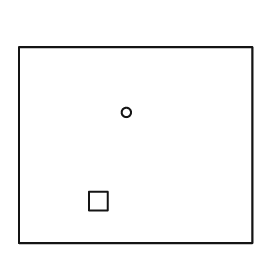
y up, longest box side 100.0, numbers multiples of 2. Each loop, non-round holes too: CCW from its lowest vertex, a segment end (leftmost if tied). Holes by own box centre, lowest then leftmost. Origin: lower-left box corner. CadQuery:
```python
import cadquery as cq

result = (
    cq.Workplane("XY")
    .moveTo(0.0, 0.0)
    .lineTo(100.0, 0.0)
    .lineTo(100.0, 84.0)
    .lineTo(0.0, 84.0)
    .close()
    .moveTo(30.0, 14.0)
    .lineTo(38.0, 14.0)
    .lineTo(38.0, 22.0)
    .lineTo(30.0, 22.0)
    .close()
    .moveTo(46.0, 56.0)
    .circle(2.0)
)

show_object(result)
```